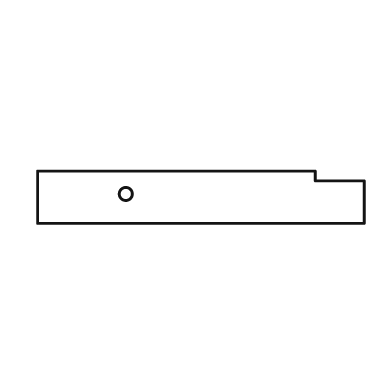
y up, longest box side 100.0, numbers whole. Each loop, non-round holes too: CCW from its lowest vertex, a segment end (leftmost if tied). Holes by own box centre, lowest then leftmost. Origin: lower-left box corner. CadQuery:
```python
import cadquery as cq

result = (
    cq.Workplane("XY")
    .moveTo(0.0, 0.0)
    .lineTo(100.0, 0.0)
    .lineTo(100.0, 13.0)
    .lineTo(85.0, 13.0)
    .lineTo(85.0, 16.0)
    .lineTo(0.0, 16.0)
    .close()
    .moveTo(27.0, 9.0)
    .circle(2.0)
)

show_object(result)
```